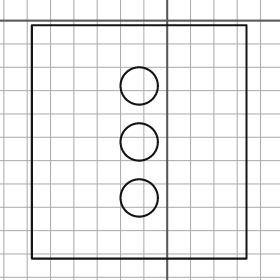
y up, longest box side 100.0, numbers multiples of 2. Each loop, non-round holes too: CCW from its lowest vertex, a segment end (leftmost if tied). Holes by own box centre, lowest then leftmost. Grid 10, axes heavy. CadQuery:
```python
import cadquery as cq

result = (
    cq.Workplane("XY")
    .moveTo(-58.0, -102.0)
    .lineTo(34.0, -102.0)
    .lineTo(34.0, -2.0)
    .lineTo(-58.0, -2.0)
    .close()
    .moveTo(-12.0, -76.0)
    .circle(8.0)
    .moveTo(-12.0, -52.0)
    .circle(8.0)
    .moveTo(-12.0, -28.0)
    .circle(8.0)
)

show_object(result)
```